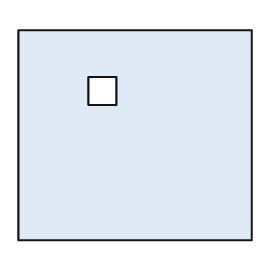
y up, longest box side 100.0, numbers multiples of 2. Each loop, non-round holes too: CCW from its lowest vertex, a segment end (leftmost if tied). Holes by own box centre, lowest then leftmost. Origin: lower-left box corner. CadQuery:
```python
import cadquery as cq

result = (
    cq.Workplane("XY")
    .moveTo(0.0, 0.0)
    .lineTo(100.0, 0.0)
    .lineTo(100.0, 90.0)
    .lineTo(0.0, 90.0)
    .close()
    .moveTo(30.0, 58.0)
    .lineTo(42.0, 58.0)
    .lineTo(42.0, 70.0)
    .lineTo(30.0, 70.0)
    .close()
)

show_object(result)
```